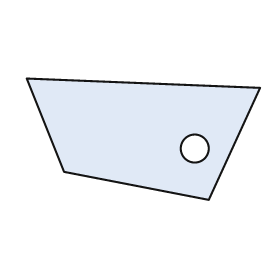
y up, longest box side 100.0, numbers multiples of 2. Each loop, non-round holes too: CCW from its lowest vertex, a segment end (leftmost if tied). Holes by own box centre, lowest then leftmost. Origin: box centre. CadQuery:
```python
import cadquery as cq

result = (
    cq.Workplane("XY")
    .moveTo(28.0, -26.0)
    .lineTo(50.0, 22.0)
    .lineTo(-50.0, 26.0)
    .lineTo(-34.0, -14.0)
    .close()
    .moveTo(22.0, -4.0)
    .circle(6.0)
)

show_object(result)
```